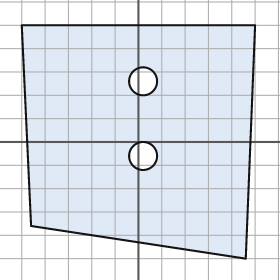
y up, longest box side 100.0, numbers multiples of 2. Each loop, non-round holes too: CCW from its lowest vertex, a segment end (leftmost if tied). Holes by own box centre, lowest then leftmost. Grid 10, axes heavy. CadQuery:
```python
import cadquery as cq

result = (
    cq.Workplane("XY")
    .moveTo(46.0, -50.0)
    .lineTo(50.0, 50.0)
    .lineTo(-50.0, 50.0)
    .lineTo(-46.0, -36.0)
    .close()
    .moveTo(2.0, -6.0)
    .circle(6.0)
    .moveTo(2.0, 26.0)
    .circle(6.0)
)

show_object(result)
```